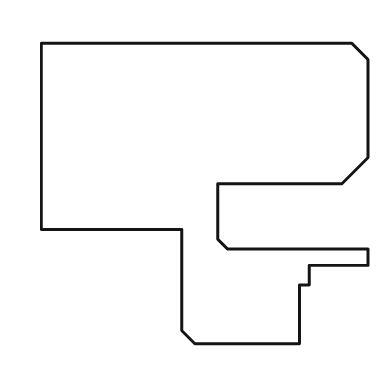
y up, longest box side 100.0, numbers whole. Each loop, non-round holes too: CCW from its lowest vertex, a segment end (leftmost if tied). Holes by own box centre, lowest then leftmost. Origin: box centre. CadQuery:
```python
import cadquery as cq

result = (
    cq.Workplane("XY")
    .moveTo(-3.0, -46.0)
    .lineTo(29.0, -46.0)
    .lineTo(29.0, -28.0)
    .lineTo(32.0, -28.0)
    .lineTo(32.0, -22.0)
    .lineTo(50.0, -22.0)
    .lineTo(50.0, -17.0)
    .lineTo(7.0, -17.0)
    .lineTo(4.0, -14.0)
    .lineTo(4.0, 3.0)
    .lineTo(42.0, 3.0)
    .lineTo(50.0, 11.0)
    .lineTo(50.0, 41.0)
    .lineTo(45.0, 46.0)
    .lineTo(-50.0, 46.0)
    .lineTo(-50.0, -11.0)
    .lineTo(-7.0, -11.0)
    .lineTo(-7.0, -42.0)
    .close()
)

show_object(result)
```